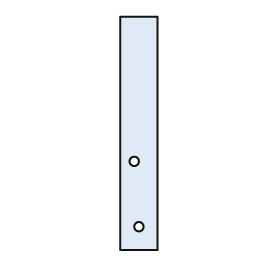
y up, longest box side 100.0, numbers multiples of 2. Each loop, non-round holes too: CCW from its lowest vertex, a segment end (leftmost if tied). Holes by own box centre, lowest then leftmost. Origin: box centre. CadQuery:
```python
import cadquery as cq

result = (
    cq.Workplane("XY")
    .moveTo(-8.0, -50.0)
    .lineTo(8.0, -50.0)
    .lineTo(8.0, 50.0)
    .lineTo(-8.0, 50.0)
    .close()
    .moveTo(0.0, -40.0)
    .circle(2.0)
    .moveTo(-2.0, -12.0)
    .circle(2.0)
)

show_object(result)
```